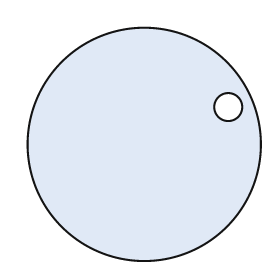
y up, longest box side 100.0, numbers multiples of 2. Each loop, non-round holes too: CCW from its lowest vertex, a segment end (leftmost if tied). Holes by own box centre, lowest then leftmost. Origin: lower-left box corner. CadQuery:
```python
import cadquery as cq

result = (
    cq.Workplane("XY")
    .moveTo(50.0, 50.0)
    .circle(50.0)
    .moveTo(86.0, 66.0)
    .circle(6.0)
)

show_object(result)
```